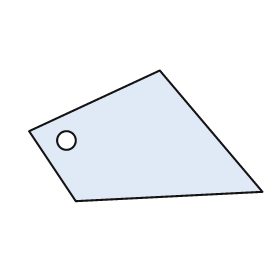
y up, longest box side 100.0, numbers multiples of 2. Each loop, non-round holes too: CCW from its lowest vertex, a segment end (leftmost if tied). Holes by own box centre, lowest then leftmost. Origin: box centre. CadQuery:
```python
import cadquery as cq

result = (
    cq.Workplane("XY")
    .moveTo(-30.0, -28.0)
    .lineTo(50.0, -24.0)
    .lineTo(6.0, 28.0)
    .lineTo(-50.0, 2.0)
    .close()
    .moveTo(-34.0, -2.0)
    .circle(4.0)
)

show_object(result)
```